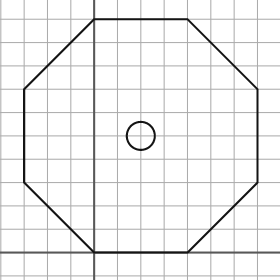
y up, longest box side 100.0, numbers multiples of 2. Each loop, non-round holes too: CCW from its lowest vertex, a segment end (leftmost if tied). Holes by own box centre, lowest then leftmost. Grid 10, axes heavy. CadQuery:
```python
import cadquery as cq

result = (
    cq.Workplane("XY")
    .moveTo(0.0, 0.0)
    .lineTo(40.0, 0.0)
    .lineTo(70.0, 30.0)
    .lineTo(70.0, 70.0)
    .lineTo(40.0, 100.0)
    .lineTo(0.0, 100.0)
    .lineTo(-30.0, 70.0)
    .lineTo(-30.0, 30.0)
    .close()
    .moveTo(20.0, 50.0)
    .circle(6.0)
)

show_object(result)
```